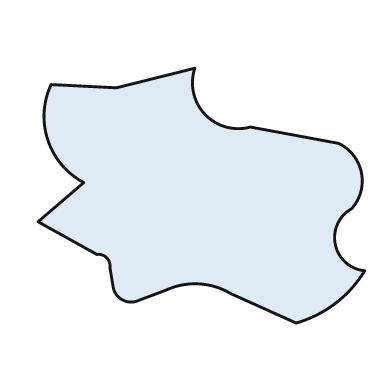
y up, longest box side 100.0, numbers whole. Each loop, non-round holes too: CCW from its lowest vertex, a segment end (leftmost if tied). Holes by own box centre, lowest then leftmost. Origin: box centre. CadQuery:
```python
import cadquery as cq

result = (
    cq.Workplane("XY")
    .moveTo(29.0, -39.0)
    .threePointArc((41.0, -33.0), (50.0, -23.0))
    .threePointArc((41.0, -15.0), (46.0, -4.0))
    .threePointArc((49.0, 7.0), (42.0, 16.0))
    .lineTo(15.0, 21.0)
    .threePointArc((1.0, 25.0), (-2.0, 39.0))
    .lineTo(-26.0, 33.0)
    .lineTo(-46.0, 34.0)
    .threePointArc((-47.0, 17.0), (-36.0, 4.0))
    .lineTo(-50.0, -8.0)
    .lineTo(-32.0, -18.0)
    .threePointArc((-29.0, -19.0), (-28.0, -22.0))
    .lineTo(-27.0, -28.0)
    .threePointArc((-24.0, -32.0), (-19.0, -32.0))
    .lineTo(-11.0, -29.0)
    .threePointArc((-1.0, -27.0), (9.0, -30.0))
    .close()
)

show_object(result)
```